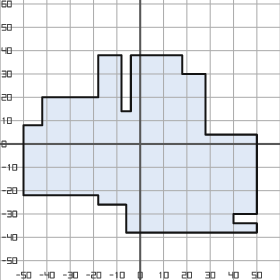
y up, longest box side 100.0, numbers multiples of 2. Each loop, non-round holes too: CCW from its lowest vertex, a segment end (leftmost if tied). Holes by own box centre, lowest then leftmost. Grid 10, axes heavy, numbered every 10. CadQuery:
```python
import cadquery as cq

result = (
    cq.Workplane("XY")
    .moveTo(-6.0, -38.0)
    .lineTo(50.0, -38.0)
    .lineTo(50.0, -34.0)
    .lineTo(40.0, -34.0)
    .lineTo(40.0, -30.0)
    .lineTo(50.0, -30.0)
    .lineTo(50.0, 4.0)
    .lineTo(28.0, 4.0)
    .lineTo(28.0, 30.0)
    .lineTo(18.0, 30.0)
    .lineTo(18.0, 38.0)
    .lineTo(-4.0, 38.0)
    .lineTo(-4.0, 14.0)
    .lineTo(-8.0, 14.0)
    .lineTo(-8.0, 38.0)
    .lineTo(-18.0, 38.0)
    .lineTo(-18.0, 20.0)
    .lineTo(-42.0, 20.0)
    .lineTo(-42.0, 8.0)
    .lineTo(-50.0, 8.0)
    .lineTo(-50.0, -22.0)
    .lineTo(-18.0, -22.0)
    .lineTo(-18.0, -26.0)
    .lineTo(-6.0, -26.0)
    .close()
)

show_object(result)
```